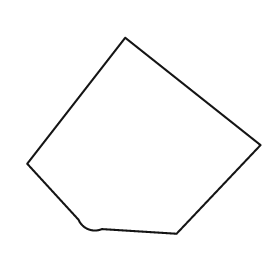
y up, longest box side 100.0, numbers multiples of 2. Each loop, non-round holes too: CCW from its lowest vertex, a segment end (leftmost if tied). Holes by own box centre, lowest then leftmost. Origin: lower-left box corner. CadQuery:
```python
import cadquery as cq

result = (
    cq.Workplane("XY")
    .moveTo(64.0, 0.0)
    .lineTo(100.0, 38.0)
    .lineTo(42.0, 84.0)
    .lineTo(0.0, 30.0)
    .lineTo(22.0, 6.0)
    .threePointArc((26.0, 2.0), (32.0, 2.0))
    .close()
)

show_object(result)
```